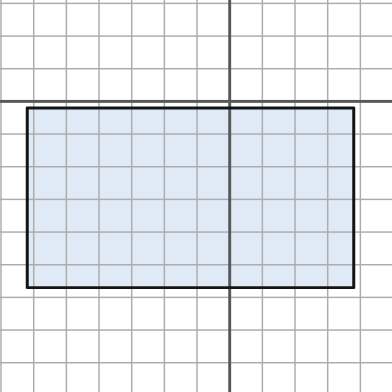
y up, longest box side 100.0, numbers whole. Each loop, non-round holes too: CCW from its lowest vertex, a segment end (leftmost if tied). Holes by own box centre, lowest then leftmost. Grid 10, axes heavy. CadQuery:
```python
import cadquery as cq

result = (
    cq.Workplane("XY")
    .moveTo(-62.0, -57.0)
    .lineTo(38.0, -57.0)
    .lineTo(38.0, -2.0)
    .lineTo(-62.0, -2.0)
    .close()
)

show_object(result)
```